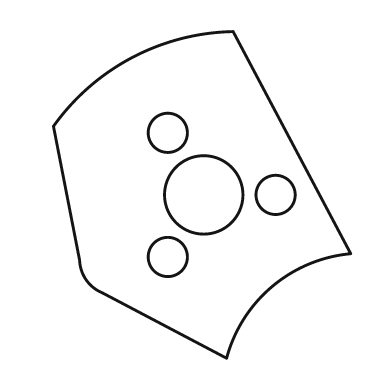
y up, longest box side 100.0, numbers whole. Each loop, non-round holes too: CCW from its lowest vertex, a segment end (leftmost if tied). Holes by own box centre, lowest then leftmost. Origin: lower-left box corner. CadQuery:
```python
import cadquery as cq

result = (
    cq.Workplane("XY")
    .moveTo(53.0, 0.0)
    .threePointArc((67.0, 22.0), (91.0, 32.0))
    .lineTo(55.0, 100.0)
    .threePointArc((24.0, 92.0), (0.0, 71.0))
    .lineTo(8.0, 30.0)
    .threePointArc((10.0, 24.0), (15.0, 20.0))
    .close()
    .moveTo(35.0, 31.0)
    .circle(6.0)
    .moveTo(46.0, 50.0)
    .circle(12.0)
    .moveTo(68.0, 50.0)
    .circle(6.0)
    .moveTo(35.0, 69.0)
    .circle(6.0)
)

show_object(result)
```